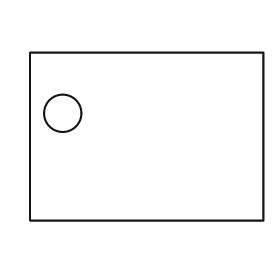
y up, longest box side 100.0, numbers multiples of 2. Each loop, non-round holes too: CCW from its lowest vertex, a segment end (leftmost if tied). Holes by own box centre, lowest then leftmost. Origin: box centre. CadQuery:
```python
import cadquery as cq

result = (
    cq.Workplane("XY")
    .moveTo(-50.0, -36.0)
    .lineTo(50.0, -36.0)
    .lineTo(50.0, 36.0)
    .lineTo(-50.0, 36.0)
    .close()
    .moveTo(-36.0, 10.0)
    .circle(8.0)
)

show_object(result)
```